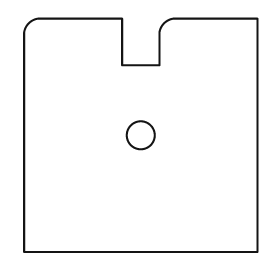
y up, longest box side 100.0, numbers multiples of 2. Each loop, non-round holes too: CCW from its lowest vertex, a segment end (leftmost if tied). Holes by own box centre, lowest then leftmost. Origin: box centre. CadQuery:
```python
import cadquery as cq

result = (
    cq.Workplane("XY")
    .moveTo(-50.0, -50.0)
    .lineTo(50.0, -50.0)
    .lineTo(50.0, 50.0)
    .lineTo(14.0, 50.0)
    .threePointArc((10.0, 48.0), (8.0, 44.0))
    .lineTo(8.0, 30.0)
    .lineTo(-8.0, 30.0)
    .lineTo(-8.0, 50.0)
    .lineTo(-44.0, 50.0)
    .threePointArc((-48.0, 48.0), (-50.0, 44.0))
    .close()
    .moveTo(0.0, 0.0)
    .circle(6.0)
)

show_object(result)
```